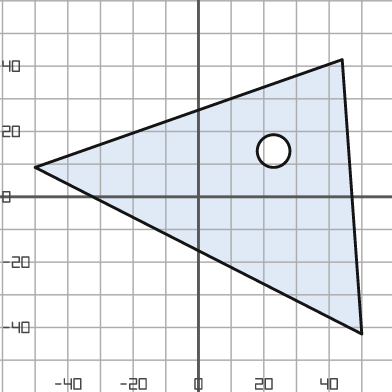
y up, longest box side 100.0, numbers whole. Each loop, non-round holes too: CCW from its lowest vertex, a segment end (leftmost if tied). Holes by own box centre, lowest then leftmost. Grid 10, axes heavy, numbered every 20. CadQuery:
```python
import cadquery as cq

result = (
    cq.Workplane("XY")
    .moveTo(50.0, -42.0)
    .lineTo(44.0, 42.0)
    .lineTo(-50.0, 9.0)
    .close()
    .moveTo(23.0, 14.0)
    .circle(5.0)
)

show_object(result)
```